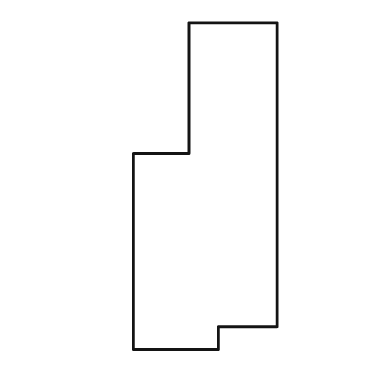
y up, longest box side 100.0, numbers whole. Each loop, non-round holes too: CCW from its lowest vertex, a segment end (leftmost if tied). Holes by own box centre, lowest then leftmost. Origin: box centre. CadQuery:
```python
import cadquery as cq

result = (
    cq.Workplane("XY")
    .moveTo(-22.0, -50.0)
    .lineTo(4.0, -50.0)
    .lineTo(4.0, -43.0)
    .lineTo(22.0, -43.0)
    .lineTo(22.0, 50.0)
    .lineTo(-5.0, 50.0)
    .lineTo(-5.0, 10.0)
    .lineTo(-22.0, 10.0)
    .close()
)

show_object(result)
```